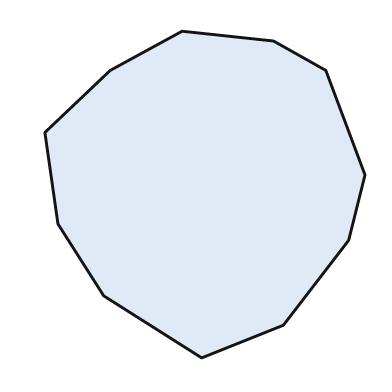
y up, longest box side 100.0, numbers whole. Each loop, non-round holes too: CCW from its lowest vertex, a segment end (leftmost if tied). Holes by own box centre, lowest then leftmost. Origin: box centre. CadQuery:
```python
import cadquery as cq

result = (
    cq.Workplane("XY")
    .moveTo(-1.0, -50.0)
    .lineTo(24.0, -40.0)
    .lineTo(44.0, -14.0)
    .lineTo(49.0, 6.0)
    .lineTo(37.0, 38.0)
    .lineTo(21.0, 47.0)
    .lineTo(-7.0, 50.0)
    .lineTo(-29.0, 38.0)
    .lineTo(-49.0, 19.0)
    .lineTo(-45.0, -9.0)
    .lineTo(-31.0, -31.0)
    .close()
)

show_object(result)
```